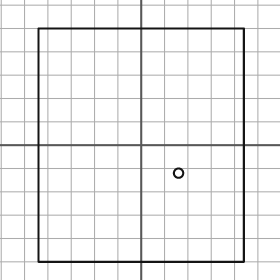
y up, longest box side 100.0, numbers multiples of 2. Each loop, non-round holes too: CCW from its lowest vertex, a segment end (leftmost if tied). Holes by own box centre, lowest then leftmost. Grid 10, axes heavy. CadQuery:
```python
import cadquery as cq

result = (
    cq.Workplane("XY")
    .moveTo(-44.0, -50.0)
    .lineTo(44.0, -50.0)
    .lineTo(44.0, 50.0)
    .lineTo(-44.0, 50.0)
    .close()
    .moveTo(16.0, -12.0)
    .circle(2.0)
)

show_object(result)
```